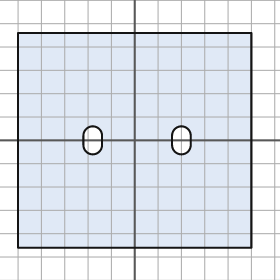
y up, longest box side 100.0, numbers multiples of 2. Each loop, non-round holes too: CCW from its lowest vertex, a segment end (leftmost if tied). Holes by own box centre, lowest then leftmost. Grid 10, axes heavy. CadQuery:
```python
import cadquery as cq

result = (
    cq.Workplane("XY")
    .moveTo(-50.0, -46.0)
    .lineTo(50.0, -46.0)
    .lineTo(50.0, 46.0)
    .lineTo(-50.0, 46.0)
    .close()
    .moveTo(-22.0, -2.0)
    .threePointArc((-18.0, -6.0), (-14.0, -2.0))
    .lineTo(-14.0, 2.0)
    .threePointArc((-18.0, 6.0), (-22.0, 2.0))
    .close()
    .moveTo(16.0, -2.0)
    .threePointArc((20.0, -6.0), (24.0, -2.0))
    .lineTo(24.0, 2.0)
    .threePointArc((20.0, 6.0), (16.0, 2.0))
    .close()
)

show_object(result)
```